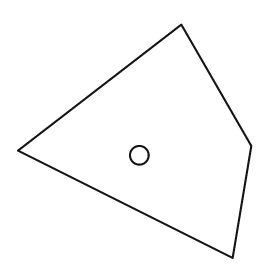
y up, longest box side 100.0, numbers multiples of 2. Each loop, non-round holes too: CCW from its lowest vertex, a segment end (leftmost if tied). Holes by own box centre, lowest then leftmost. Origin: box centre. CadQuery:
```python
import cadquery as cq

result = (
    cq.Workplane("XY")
    .moveTo(42.0, -50.0)
    .lineTo(50.0, -2.0)
    .lineTo(20.0, 50.0)
    .lineTo(-50.0, -4.0)
    .close()
    .moveTo(2.0, -6.0)
    .circle(4.0)
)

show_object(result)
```